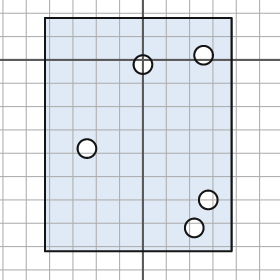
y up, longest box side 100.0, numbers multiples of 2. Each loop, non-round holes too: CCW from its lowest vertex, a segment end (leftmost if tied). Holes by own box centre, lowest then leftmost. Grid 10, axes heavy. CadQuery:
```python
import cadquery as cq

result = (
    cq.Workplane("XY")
    .moveTo(-42.0, -82.0)
    .lineTo(38.0, -82.0)
    .lineTo(38.0, 18.0)
    .lineTo(-42.0, 18.0)
    .close()
    .moveTo(22.0, -72.0)
    .circle(4.0)
    .moveTo(28.0, -60.0)
    .circle(4.0)
    .moveTo(-24.0, -38.0)
    .circle(4.0)
    .moveTo(0.0, -2.0)
    .circle(4.0)
    .moveTo(26.0, 2.0)
    .circle(4.0)
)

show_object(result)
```